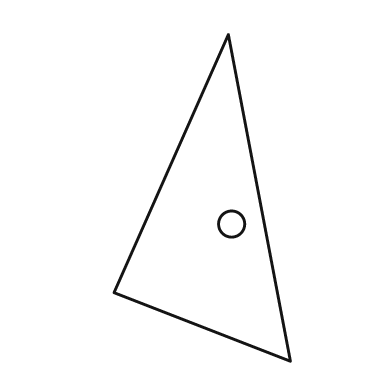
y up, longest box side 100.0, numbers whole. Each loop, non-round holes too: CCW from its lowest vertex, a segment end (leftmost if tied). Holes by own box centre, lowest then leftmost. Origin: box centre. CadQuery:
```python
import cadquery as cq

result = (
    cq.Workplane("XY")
    .moveTo(27.0, -50.0)
    .lineTo(8.0, 50.0)
    .lineTo(-27.0, -29.0)
    .close()
    .moveTo(9.0, -8.0)
    .circle(4.0)
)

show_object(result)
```